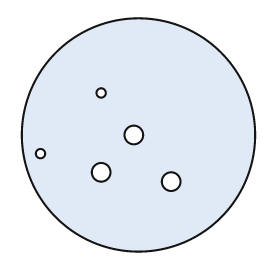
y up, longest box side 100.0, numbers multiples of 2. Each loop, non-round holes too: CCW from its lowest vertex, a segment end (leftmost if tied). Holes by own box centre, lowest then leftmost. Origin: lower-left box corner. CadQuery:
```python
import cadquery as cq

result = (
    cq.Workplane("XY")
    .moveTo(50.0, 50.0)
    .circle(50.0)
    .moveTo(64.0, 30.0)
    .circle(4.0)
    .moveTo(34.0, 34.0)
    .circle(4.0)
    .moveTo(8.0, 42.0)
    .circle(2.0)
    .moveTo(48.0, 50.0)
    .circle(4.0)
    .moveTo(34.0, 68.0)
    .circle(2.0)
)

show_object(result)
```